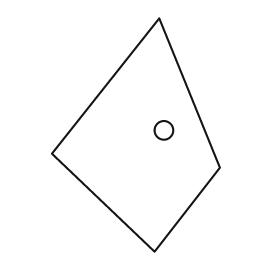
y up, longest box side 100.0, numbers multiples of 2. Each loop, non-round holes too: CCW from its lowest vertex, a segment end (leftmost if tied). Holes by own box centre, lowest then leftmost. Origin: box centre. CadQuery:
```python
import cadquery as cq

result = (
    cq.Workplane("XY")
    .moveTo(8.0, -50.0)
    .lineTo(36.0, -14.0)
    .lineTo(10.0, 50.0)
    .lineTo(-36.0, -8.0)
    .close()
    .moveTo(12.0, 2.0)
    .circle(4.0)
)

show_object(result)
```